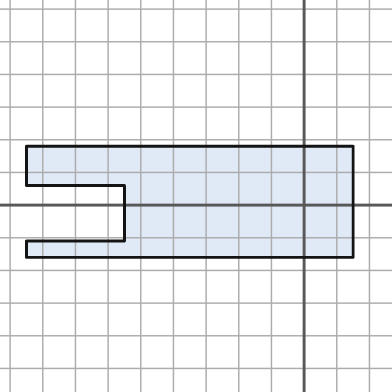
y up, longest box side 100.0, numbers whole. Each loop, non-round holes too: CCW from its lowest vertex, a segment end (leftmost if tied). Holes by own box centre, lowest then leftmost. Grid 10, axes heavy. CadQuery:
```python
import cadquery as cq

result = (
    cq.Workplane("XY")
    .moveTo(-85.0, -16.0)
    .lineTo(15.0, -16.0)
    .lineTo(15.0, 18.0)
    .lineTo(-85.0, 18.0)
    .lineTo(-85.0, 6.0)
    .lineTo(-55.0, 6.0)
    .lineTo(-55.0, -11.0)
    .lineTo(-85.0, -11.0)
    .close()
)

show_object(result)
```